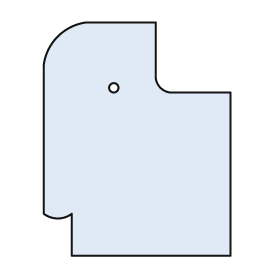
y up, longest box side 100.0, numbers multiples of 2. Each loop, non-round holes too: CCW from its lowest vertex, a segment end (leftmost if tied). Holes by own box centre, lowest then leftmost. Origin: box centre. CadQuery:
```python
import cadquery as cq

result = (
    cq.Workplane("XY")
    .moveTo(-28.0, -50.0)
    .lineTo(40.0, -50.0)
    .lineTo(40.0, 20.0)
    .lineTo(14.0, 20.0)
    .threePointArc((10.0, 22.0), (8.0, 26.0))
    .lineTo(8.0, 50.0)
    .lineTo(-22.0, 50.0)
    .threePointArc((-34.0, 44.0), (-40.0, 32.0))
    .lineTo(-40.0, -32.0)
    .threePointArc((-34.0, -34.0), (-28.0, -32.0))
    .close()
    .moveTo(-10.0, 22.0)
    .circle(2.0)
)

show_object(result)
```